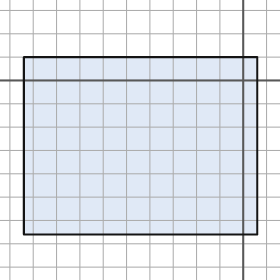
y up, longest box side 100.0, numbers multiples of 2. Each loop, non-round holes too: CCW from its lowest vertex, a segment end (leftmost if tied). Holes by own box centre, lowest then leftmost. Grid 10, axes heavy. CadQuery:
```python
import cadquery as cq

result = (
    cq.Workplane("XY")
    .moveTo(-94.0, -66.0)
    .lineTo(6.0, -66.0)
    .lineTo(6.0, 10.0)
    .lineTo(-94.0, 10.0)
    .close()
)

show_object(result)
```